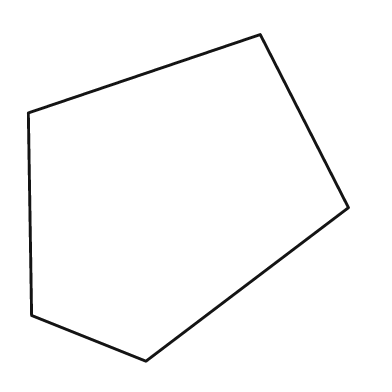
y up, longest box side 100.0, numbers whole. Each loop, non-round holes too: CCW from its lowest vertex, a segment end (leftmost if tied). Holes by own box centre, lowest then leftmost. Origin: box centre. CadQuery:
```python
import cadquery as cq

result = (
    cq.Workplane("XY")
    .moveTo(-13.0, -50.0)
    .lineTo(49.0, -3.0)
    .lineTo(22.0, 50.0)
    .lineTo(-49.0, 26.0)
    .lineTo(-48.0, -36.0)
    .close()
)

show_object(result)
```